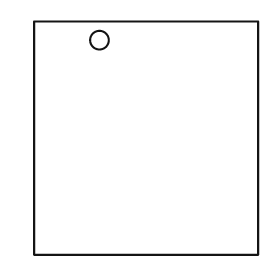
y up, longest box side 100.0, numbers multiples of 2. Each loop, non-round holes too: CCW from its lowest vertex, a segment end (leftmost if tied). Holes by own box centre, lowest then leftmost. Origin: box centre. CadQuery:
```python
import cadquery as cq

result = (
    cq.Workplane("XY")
    .moveTo(-48.0, -50.0)
    .lineTo(48.0, -50.0)
    .lineTo(48.0, 50.0)
    .lineTo(-48.0, 50.0)
    .close()
    .moveTo(-20.0, 42.0)
    .circle(4.0)
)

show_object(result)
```